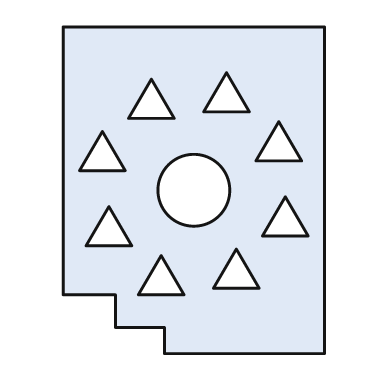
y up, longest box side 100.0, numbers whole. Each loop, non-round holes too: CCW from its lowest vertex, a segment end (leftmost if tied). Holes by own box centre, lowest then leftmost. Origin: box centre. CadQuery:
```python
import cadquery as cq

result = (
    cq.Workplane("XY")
    .moveTo(-9.0, -50.0)
    .lineTo(40.0, -50.0)
    .lineTo(40.0, 50.0)
    .lineTo(-40.0, 50.0)
    .lineTo(-40.0, -32.0)
    .lineTo(-24.0, -32.0)
    .lineTo(-24.0, -42.0)
    .lineTo(-9.0, -42.0)
    .close()
    .moveTo(-17.0, -32.0)
    .lineTo(-3.0, -32.0)
    .lineTo(-10.0, -20.0)
    .close()
    .moveTo(6.0, -30.0)
    .lineTo(20.0, -30.0)
    .lineTo(13.0, -18.0)
    .close()
    .moveTo(-33.0, -17.0)
    .lineTo(-19.0, -17.0)
    .lineTo(-26.0, -5.0)
    .close()
    .moveTo(21.0, -14.0)
    .lineTo(35.0, -14.0)
    .lineTo(28.0, -2.0)
    .close()
    .moveTo(0.0, 0.0)
    .circle(11.0)
    .moveTo(-35.0, 6.0)
    .lineTo(-21.0, 6.0)
    .lineTo(-28.0, 18.0)
    .close()
    .moveTo(19.0, 9.0)
    .lineTo(33.0, 9.0)
    .lineTo(26.0, 21.0)
    .close()
    .moveTo(-20.0, 22.0)
    .lineTo(-6.0, 22.0)
    .lineTo(-13.0, 34.0)
    .close()
    .moveTo(3.0, 24.0)
    .lineTo(17.0, 24.0)
    .lineTo(10.0, 36.0)
    .close()
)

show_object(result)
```